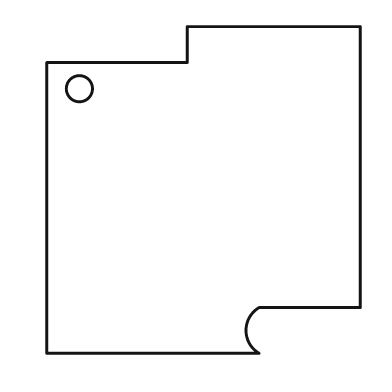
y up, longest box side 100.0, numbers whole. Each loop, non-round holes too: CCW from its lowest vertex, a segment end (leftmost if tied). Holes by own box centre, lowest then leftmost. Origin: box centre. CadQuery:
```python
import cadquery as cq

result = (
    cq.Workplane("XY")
    .moveTo(-48.0, -50.0)
    .lineTo(17.0, -50.0)
    .threePointArc((13.0, -43.0), (17.0, -36.0))
    .lineTo(48.0, -36.0)
    .lineTo(48.0, 50.0)
    .lineTo(-5.0, 50.0)
    .lineTo(-5.0, 39.0)
    .lineTo(-48.0, 39.0)
    .close()
    .moveTo(-38.0, 31.0)
    .circle(4.0)
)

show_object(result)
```